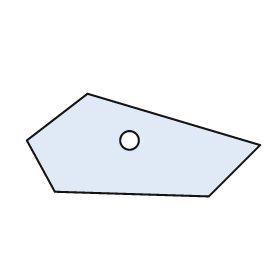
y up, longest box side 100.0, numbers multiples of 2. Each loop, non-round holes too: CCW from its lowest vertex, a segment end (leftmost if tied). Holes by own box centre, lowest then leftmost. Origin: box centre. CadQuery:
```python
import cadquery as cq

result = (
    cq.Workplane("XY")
    .moveTo(28.0, -22.0)
    .lineTo(50.0, 0.0)
    .lineTo(-24.0, 22.0)
    .lineTo(-50.0, 2.0)
    .lineTo(-38.0, -20.0)
    .close()
    .moveTo(-6.0, 2.0)
    .circle(4.0)
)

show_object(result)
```